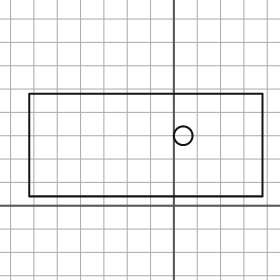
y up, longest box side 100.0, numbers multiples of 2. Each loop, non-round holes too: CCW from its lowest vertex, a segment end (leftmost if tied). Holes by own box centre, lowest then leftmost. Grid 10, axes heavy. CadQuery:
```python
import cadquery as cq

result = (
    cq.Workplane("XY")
    .moveTo(-62.0, 4.0)
    .lineTo(38.0, 4.0)
    .lineTo(38.0, 48.0)
    .lineTo(-62.0, 48.0)
    .close()
    .moveTo(4.0, 30.0)
    .circle(4.0)
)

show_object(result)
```